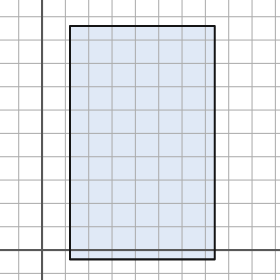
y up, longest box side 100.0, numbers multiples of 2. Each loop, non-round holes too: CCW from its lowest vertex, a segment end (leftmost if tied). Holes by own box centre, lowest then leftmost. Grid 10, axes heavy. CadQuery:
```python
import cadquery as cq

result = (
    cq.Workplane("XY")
    .moveTo(12.0, -4.0)
    .lineTo(74.0, -4.0)
    .lineTo(74.0, 96.0)
    .lineTo(12.0, 96.0)
    .close()
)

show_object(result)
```